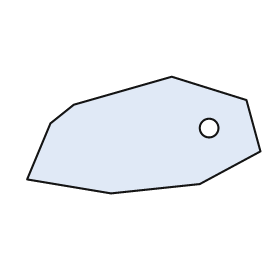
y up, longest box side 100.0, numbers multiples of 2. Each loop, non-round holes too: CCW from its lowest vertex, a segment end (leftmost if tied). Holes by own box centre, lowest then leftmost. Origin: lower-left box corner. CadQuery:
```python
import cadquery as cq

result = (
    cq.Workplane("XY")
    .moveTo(36.0, 0.0)
    .lineTo(74.0, 4.0)
    .lineTo(100.0, 18.0)
    .lineTo(94.0, 40.0)
    .lineTo(62.0, 50.0)
    .lineTo(20.0, 38.0)
    .lineTo(10.0, 30.0)
    .lineTo(0.0, 6.0)
    .close()
    .moveTo(78.0, 28.0)
    .circle(4.0)
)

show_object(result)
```